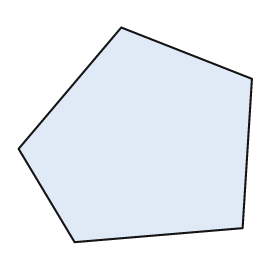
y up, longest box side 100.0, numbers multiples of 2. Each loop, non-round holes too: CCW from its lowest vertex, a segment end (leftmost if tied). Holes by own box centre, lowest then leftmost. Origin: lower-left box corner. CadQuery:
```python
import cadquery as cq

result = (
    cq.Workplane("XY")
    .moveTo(24.0, 0.0)
    .lineTo(96.0, 6.0)
    .lineTo(100.0, 70.0)
    .lineTo(44.0, 92.0)
    .lineTo(0.0, 40.0)
    .close()
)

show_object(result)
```